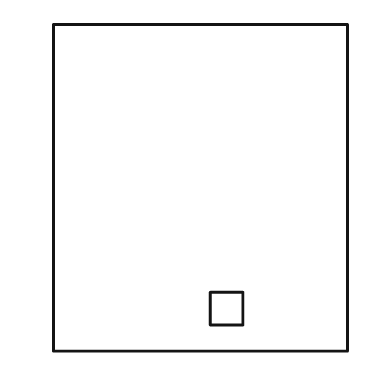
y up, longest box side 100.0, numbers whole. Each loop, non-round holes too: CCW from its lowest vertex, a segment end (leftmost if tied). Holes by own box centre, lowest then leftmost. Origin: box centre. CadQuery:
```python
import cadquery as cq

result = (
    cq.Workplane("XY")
    .moveTo(-45.0, -50.0)
    .lineTo(45.0, -50.0)
    .lineTo(45.0, 50.0)
    .lineTo(-45.0, 50.0)
    .close()
    .moveTo(3.0, -42.0)
    .lineTo(13.0, -42.0)
    .lineTo(13.0, -32.0)
    .lineTo(3.0, -32.0)
    .close()
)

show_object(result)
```